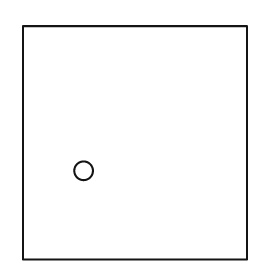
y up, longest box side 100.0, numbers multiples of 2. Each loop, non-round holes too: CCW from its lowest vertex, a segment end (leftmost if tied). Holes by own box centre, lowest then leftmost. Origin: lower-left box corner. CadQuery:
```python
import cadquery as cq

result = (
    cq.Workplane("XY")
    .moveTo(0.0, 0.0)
    .lineTo(96.0, 0.0)
    .lineTo(96.0, 100.0)
    .lineTo(0.0, 100.0)
    .close()
    .moveTo(26.0, 38.0)
    .circle(4.0)
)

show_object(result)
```